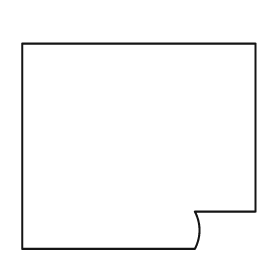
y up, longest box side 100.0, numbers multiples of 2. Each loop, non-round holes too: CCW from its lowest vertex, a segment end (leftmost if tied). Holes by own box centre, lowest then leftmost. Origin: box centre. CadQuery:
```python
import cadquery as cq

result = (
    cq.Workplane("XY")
    .moveTo(-50.0, -44.0)
    .lineTo(24.0, -44.0)
    .threePointArc((26.0, -36.0), (24.0, -28.0))
    .lineTo(50.0, -28.0)
    .lineTo(50.0, 44.0)
    .lineTo(-50.0, 44.0)
    .close()
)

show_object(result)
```